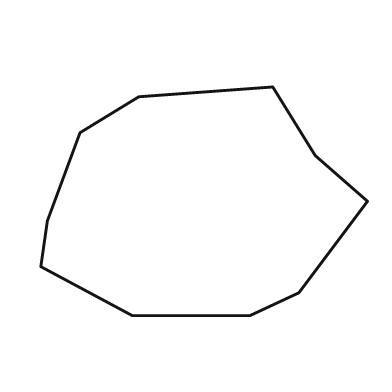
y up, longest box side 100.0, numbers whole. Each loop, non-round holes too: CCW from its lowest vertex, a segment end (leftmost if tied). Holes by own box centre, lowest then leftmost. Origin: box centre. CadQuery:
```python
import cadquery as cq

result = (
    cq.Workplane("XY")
    .moveTo(-22.0, -35.0)
    .lineTo(14.0, -35.0)
    .lineTo(29.0, -28.0)
    .lineTo(50.0, 0.0)
    .lineTo(34.0, 14.0)
    .lineTo(21.0, 35.0)
    .lineTo(-20.0, 32.0)
    .lineTo(-38.0, 21.0)
    .lineTo(-48.0, -6.0)
    .lineTo(-50.0, -20.0)
    .close()
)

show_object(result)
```